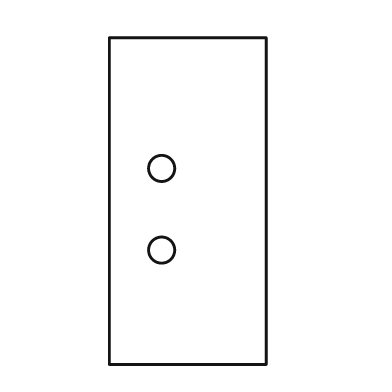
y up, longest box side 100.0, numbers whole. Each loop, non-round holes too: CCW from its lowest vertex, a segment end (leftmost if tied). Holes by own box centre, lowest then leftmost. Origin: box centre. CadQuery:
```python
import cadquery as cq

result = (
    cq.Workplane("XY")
    .moveTo(-24.0, -50.0)
    .lineTo(24.0, -50.0)
    .lineTo(24.0, 50.0)
    .lineTo(-24.0, 50.0)
    .close()
    .moveTo(-8.0, -15.0)
    .circle(4.0)
    .moveTo(-8.0, 10.0)
    .circle(4.0)
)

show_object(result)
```